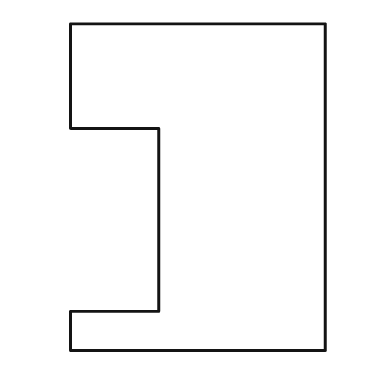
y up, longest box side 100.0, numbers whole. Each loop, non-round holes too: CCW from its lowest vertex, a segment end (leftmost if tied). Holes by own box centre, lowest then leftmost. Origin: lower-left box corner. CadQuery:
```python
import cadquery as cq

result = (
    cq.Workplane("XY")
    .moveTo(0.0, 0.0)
    .lineTo(78.0, 0.0)
    .lineTo(78.0, 100.0)
    .lineTo(0.0, 100.0)
    .lineTo(0.0, 68.0)
    .lineTo(27.0, 68.0)
    .lineTo(27.0, 12.0)
    .lineTo(0.0, 12.0)
    .close()
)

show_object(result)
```